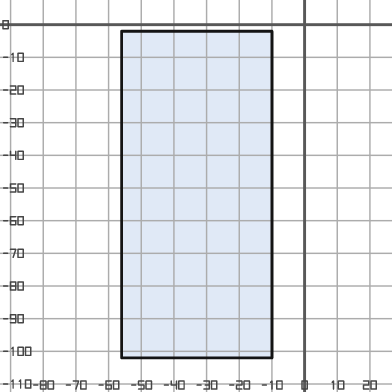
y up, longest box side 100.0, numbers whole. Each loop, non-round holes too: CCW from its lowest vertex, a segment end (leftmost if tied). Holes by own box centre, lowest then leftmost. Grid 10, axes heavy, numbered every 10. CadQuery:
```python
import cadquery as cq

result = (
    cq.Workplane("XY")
    .moveTo(-56.0, -102.0)
    .lineTo(-10.0, -102.0)
    .lineTo(-10.0, -2.0)
    .lineTo(-56.0, -2.0)
    .close()
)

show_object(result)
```